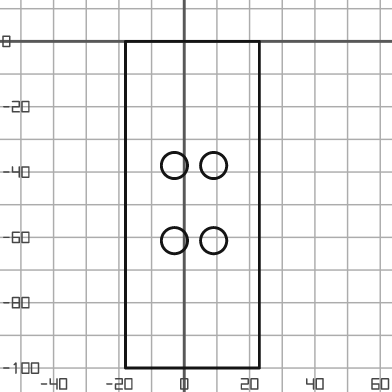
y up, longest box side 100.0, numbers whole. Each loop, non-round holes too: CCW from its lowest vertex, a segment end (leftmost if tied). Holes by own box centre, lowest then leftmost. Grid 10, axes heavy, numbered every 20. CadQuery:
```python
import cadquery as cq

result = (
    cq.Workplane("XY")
    .moveTo(-18.0, -100.0)
    .lineTo(23.0, -100.0)
    .lineTo(23.0, 0.0)
    .lineTo(-18.0, 0.0)
    .close()
    .moveTo(-3.0, -61.0)
    .circle(4.0)
    .moveTo(9.0, -61.0)
    .circle(4.0)
    .moveTo(-3.0, -38.0)
    .circle(4.0)
    .moveTo(9.0, -38.0)
    .circle(4.0)
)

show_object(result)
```